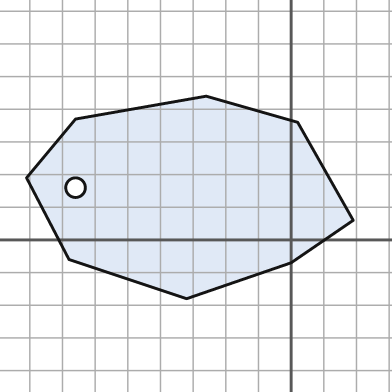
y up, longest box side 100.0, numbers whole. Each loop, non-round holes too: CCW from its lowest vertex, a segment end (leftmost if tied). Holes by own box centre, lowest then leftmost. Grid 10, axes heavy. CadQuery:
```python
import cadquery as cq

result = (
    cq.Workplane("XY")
    .moveTo(-32.0, -18.0)
    .lineTo(0.0, -7.0)
    .lineTo(19.0, 6.0)
    .lineTo(2.0, 36.0)
    .lineTo(-26.0, 44.0)
    .lineTo(-66.0, 37.0)
    .lineTo(-81.0, 19.0)
    .lineTo(-68.0, -6.0)
    .close()
    .moveTo(-66.0, 16.0)
    .circle(3.0)
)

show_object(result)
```